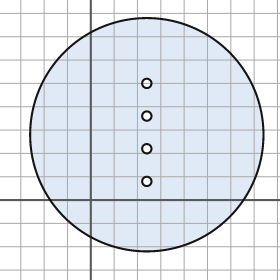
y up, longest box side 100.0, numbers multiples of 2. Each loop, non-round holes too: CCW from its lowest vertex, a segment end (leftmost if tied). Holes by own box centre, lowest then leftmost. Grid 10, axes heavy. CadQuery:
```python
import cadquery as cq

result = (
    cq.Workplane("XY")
    .moveTo(24.0, 28.0)
    .circle(50.0)
    .moveTo(24.0, 8.0)
    .circle(2.0)
    .moveTo(24.0, 22.0)
    .circle(2.0)
    .moveTo(24.0, 36.0)
    .circle(2.0)
    .moveTo(24.0, 50.0)
    .circle(2.0)
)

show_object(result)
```